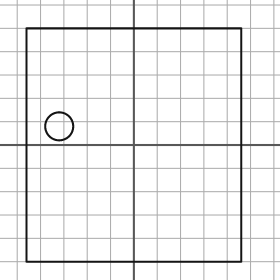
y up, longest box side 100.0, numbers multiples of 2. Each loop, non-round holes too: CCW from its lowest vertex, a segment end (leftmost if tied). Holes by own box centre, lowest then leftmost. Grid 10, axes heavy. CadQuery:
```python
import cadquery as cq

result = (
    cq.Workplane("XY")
    .moveTo(-46.0, -50.0)
    .lineTo(46.0, -50.0)
    .lineTo(46.0, 50.0)
    .lineTo(-46.0, 50.0)
    .close()
    .moveTo(-32.0, 8.0)
    .circle(6.0)
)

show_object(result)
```